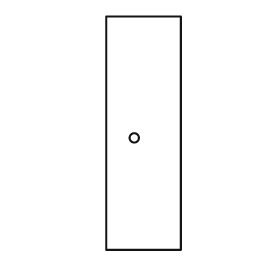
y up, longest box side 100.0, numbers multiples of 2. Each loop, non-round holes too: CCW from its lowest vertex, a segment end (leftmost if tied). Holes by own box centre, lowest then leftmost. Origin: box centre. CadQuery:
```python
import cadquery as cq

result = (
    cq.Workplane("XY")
    .moveTo(-16.0, -50.0)
    .lineTo(16.0, -50.0)
    .lineTo(16.0, 50.0)
    .lineTo(-16.0, 50.0)
    .close()
    .moveTo(-4.0, -2.0)
    .circle(2.0)
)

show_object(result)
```